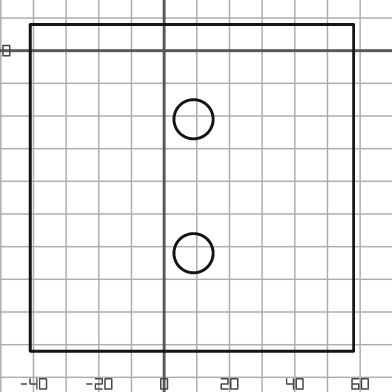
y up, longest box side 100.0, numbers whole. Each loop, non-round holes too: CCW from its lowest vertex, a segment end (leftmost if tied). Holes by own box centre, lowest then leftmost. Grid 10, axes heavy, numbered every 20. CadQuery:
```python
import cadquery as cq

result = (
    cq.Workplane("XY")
    .moveTo(-41.0, -92.0)
    .lineTo(58.0, -92.0)
    .lineTo(58.0, 8.0)
    .lineTo(-41.0, 8.0)
    .close()
    .moveTo(9.0, -62.0)
    .circle(6.0)
    .moveTo(9.0, -21.0)
    .circle(6.0)
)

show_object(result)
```